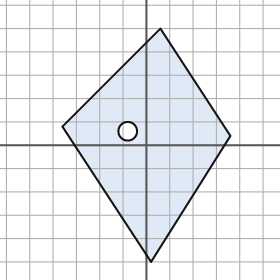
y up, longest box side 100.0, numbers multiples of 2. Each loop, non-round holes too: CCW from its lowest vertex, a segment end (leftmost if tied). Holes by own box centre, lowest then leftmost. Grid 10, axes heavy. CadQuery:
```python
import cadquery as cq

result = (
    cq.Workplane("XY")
    .moveTo(2.0, -50.0)
    .lineTo(36.0, 4.0)
    .lineTo(6.0, 50.0)
    .lineTo(-36.0, 8.0)
    .close()
    .moveTo(-8.0, 6.0)
    .circle(4.0)
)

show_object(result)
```